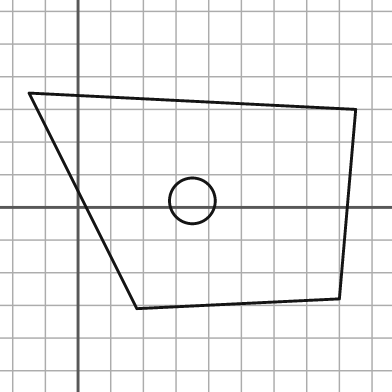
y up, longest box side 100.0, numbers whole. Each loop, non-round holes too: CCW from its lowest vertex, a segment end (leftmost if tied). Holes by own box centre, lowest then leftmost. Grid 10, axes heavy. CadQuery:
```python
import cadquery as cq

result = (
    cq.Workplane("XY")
    .moveTo(18.0, -31.0)
    .lineTo(80.0, -28.0)
    .lineTo(85.0, 30.0)
    .lineTo(-15.0, 35.0)
    .close()
    .moveTo(35.0, 2.0)
    .circle(7.0)
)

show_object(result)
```